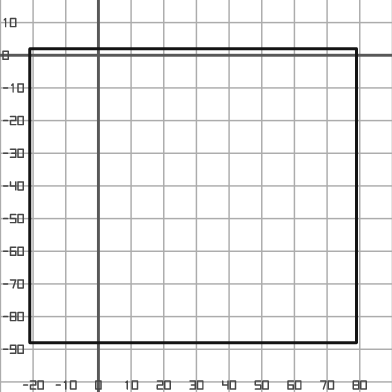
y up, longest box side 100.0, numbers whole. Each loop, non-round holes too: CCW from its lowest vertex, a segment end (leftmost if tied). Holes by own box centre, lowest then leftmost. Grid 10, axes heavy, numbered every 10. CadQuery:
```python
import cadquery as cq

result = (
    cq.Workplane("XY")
    .moveTo(-21.0, -88.0)
    .lineTo(79.0, -88.0)
    .lineTo(79.0, 2.0)
    .lineTo(-21.0, 2.0)
    .close()
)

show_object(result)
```